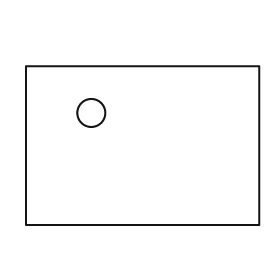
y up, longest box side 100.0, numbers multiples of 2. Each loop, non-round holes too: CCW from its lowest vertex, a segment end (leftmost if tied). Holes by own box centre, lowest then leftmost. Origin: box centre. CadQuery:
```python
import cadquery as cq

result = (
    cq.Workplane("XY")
    .moveTo(-50.0, -34.0)
    .lineTo(50.0, -34.0)
    .lineTo(50.0, 34.0)
    .lineTo(-50.0, 34.0)
    .close()
    .moveTo(-22.0, 14.0)
    .circle(6.0)
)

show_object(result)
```